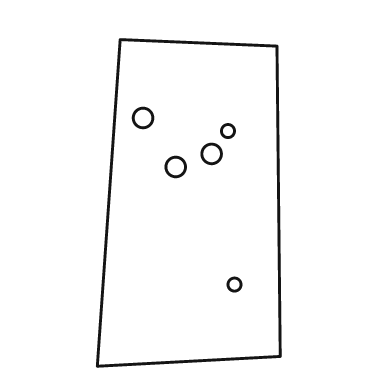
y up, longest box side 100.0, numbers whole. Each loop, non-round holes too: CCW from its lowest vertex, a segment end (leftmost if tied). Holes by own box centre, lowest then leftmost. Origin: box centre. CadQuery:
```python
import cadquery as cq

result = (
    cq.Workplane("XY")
    .moveTo(-28.0, -50.0)
    .lineTo(28.0, -47.0)
    .lineTo(27.0, 48.0)
    .lineTo(-21.0, 50.0)
    .close()
    .moveTo(14.0, -25.0)
    .circle(2.0)
    .moveTo(-4.0, 11.0)
    .circle(3.0)
    .moveTo(7.0, 15.0)
    .circle(3.0)
    .moveTo(12.0, 22.0)
    .circle(2.0)
    .moveTo(-14.0, 26.0)
    .circle(3.0)
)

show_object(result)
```